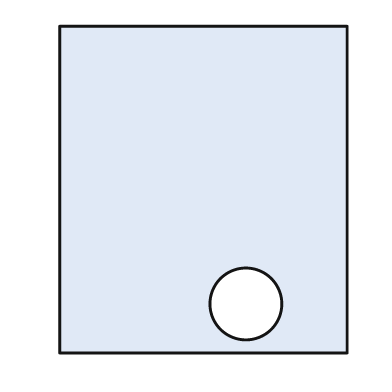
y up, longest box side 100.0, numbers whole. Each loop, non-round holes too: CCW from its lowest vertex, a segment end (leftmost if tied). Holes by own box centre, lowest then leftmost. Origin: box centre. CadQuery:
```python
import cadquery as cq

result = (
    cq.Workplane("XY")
    .moveTo(-44.0, -50.0)
    .lineTo(44.0, -50.0)
    .lineTo(44.0, 50.0)
    .lineTo(-44.0, 50.0)
    .close()
    .moveTo(13.0, -35.0)
    .circle(11.0)
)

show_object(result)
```